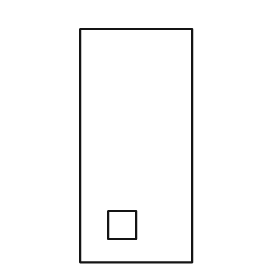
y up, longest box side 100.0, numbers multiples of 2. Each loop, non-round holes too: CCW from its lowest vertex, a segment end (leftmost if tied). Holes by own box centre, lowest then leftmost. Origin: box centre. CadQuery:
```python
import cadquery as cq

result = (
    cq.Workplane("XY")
    .moveTo(-24.0, -50.0)
    .lineTo(24.0, -50.0)
    .lineTo(24.0, 50.0)
    .lineTo(-24.0, 50.0)
    .close()
    .moveTo(-12.0, -40.0)
    .lineTo(0.0, -40.0)
    .lineTo(0.0, -28.0)
    .lineTo(-12.0, -28.0)
    .close()
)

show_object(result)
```